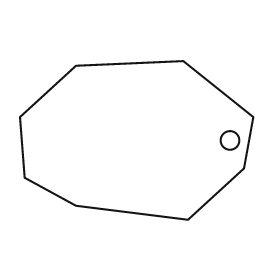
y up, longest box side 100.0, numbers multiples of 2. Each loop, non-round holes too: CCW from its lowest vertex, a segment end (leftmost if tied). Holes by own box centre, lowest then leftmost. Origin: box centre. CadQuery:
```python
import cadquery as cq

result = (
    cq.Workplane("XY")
    .moveTo(22.0, -34.0)
    .lineTo(46.0, -12.0)
    .lineTo(50.0, 10.0)
    .lineTo(20.0, 34.0)
    .lineTo(-26.0, 32.0)
    .lineTo(-50.0, 10.0)
    .lineTo(-48.0, -16.0)
    .lineTo(-26.0, -28.0)
    .close()
    .moveTo(40.0, 0.0)
    .circle(4.0)
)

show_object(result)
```